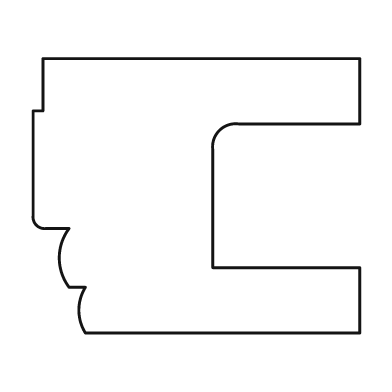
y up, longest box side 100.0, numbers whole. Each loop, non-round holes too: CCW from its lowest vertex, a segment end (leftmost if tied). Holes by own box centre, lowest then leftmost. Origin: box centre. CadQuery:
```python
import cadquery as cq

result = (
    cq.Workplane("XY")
    .moveTo(-34.0, -42.0)
    .lineTo(50.0, -42.0)
    .lineTo(50.0, -22.0)
    .lineTo(5.0, -22.0)
    .lineTo(5.0, 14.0)
    .threePointArc((7.0, 20.0), (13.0, 22.0))
    .lineTo(50.0, 22.0)
    .lineTo(50.0, 42.0)
    .lineTo(-47.0, 42.0)
    .lineTo(-47.0, 26.0)
    .lineTo(-50.0, 26.0)
    .lineTo(-50.0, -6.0)
    .threePointArc((-49.0, -9.0), (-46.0, -10.0))
    .lineTo(-39.0, -10.0)
    .threePointArc((-42.0, -19.0), (-39.0, -28.0))
    .lineTo(-34.0, -28.0)
    .threePointArc((-36.0, -35.0), (-34.0, -42.0))
    .close()
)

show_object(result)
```